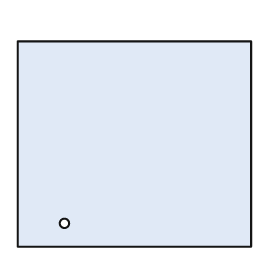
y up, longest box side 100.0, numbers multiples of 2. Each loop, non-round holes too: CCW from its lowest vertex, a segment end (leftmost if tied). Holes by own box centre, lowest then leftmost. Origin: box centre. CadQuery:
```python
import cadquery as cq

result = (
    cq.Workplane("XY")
    .moveTo(-50.0, -44.0)
    .lineTo(50.0, -44.0)
    .lineTo(50.0, 44.0)
    .lineTo(-50.0, 44.0)
    .close()
    .moveTo(-30.0, -34.0)
    .circle(2.0)
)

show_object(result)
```